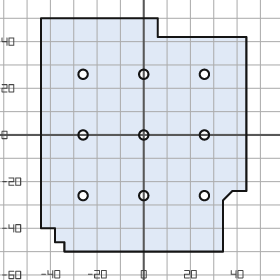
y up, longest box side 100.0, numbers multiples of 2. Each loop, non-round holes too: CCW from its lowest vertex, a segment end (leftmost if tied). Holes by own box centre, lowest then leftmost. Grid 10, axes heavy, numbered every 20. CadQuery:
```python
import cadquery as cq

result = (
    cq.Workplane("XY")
    .moveTo(-34.0, -50.0)
    .lineTo(34.0, -50.0)
    .lineTo(34.0, -28.0)
    .lineTo(38.0, -24.0)
    .lineTo(44.0, -24.0)
    .lineTo(44.0, 42.0)
    .lineTo(6.0, 42.0)
    .lineTo(6.0, 50.0)
    .lineTo(-44.0, 50.0)
    .lineTo(-44.0, -40.0)
    .lineTo(-38.0, -40.0)
    .lineTo(-38.0, -46.0)
    .lineTo(-34.0, -46.0)
    .close()
    .moveTo(-26.0, -26.0)
    .circle(2.0)
    .moveTo(0.0, -26.0)
    .circle(2.0)
    .moveTo(26.0, -26.0)
    .circle(2.0)
    .moveTo(-26.0, 0.0)
    .circle(2.0)
    .moveTo(0.0, 0.0)
    .circle(2.0)
    .moveTo(26.0, 0.0)
    .circle(2.0)
    .moveTo(-26.0, 26.0)
    .circle(2.0)
    .moveTo(0.0, 26.0)
    .circle(2.0)
    .moveTo(26.0, 26.0)
    .circle(2.0)
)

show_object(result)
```